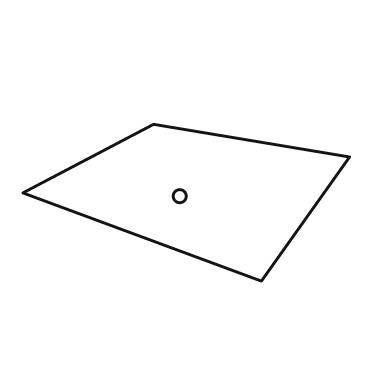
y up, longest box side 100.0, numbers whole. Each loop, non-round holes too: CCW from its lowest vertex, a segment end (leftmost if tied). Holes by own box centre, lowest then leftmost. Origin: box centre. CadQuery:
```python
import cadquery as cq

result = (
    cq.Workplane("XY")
    .moveTo(23.0, -24.0)
    .lineTo(50.0, 14.0)
    .lineTo(-10.0, 24.0)
    .lineTo(-50.0, 3.0)
    .close()
    .moveTo(-2.0, 2.0)
    .circle(2.0)
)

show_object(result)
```